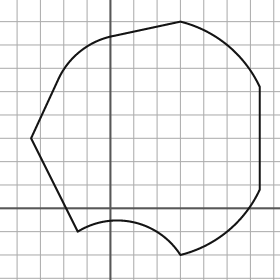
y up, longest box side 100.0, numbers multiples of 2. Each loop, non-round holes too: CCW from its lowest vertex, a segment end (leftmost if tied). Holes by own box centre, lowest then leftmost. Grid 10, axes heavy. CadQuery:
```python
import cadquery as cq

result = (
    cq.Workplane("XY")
    .moveTo(30.0, -20.0)
    .threePointArc((50.0, -10.0), (64.0, 8.0))
    .lineTo(64.0, 52.0)
    .threePointArc((50.0, 70.0), (30.0, 80.0))
    .lineTo(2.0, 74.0)
    .threePointArc((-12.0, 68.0), (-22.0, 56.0))
    .lineTo(-34.0, 30.0)
    .lineTo(-14.0, -10.0)
    .threePointArc((10.0, -6.0), (30.0, -20.0))
    .close()
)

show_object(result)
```